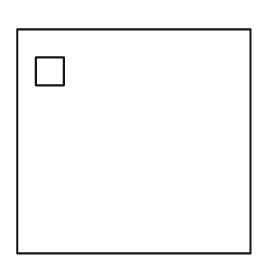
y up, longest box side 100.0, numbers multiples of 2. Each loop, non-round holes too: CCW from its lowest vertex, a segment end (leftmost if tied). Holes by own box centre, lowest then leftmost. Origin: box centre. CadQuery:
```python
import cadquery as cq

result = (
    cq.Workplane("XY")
    .moveTo(-50.0, -48.0)
    .lineTo(50.0, -48.0)
    .lineTo(50.0, 48.0)
    .lineTo(-50.0, 48.0)
    .close()
    .moveTo(-42.0, 24.0)
    .lineTo(-30.0, 24.0)
    .lineTo(-30.0, 36.0)
    .lineTo(-42.0, 36.0)
    .close()
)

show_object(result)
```